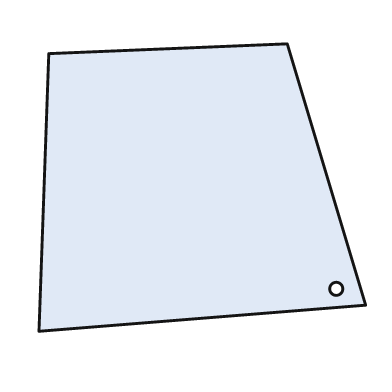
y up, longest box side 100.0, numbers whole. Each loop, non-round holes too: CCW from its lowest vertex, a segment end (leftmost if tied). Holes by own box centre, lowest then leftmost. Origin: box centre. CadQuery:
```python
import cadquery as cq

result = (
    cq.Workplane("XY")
    .moveTo(-50.0, -44.0)
    .lineTo(50.0, -36.0)
    .lineTo(26.0, 44.0)
    .lineTo(-47.0, 41.0)
    .close()
    .moveTo(41.0, -31.0)
    .circle(2.0)
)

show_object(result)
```